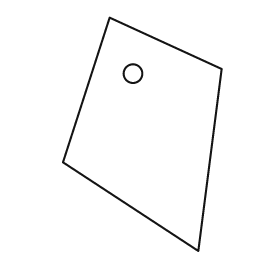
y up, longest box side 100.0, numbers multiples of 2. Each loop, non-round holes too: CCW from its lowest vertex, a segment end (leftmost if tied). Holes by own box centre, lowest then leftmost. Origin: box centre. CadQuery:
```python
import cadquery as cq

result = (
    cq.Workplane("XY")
    .moveTo(24.0, -50.0)
    .lineTo(34.0, 28.0)
    .lineTo(-14.0, 50.0)
    .lineTo(-34.0, -12.0)
    .close()
    .moveTo(-4.0, 26.0)
    .circle(4.0)
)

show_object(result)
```